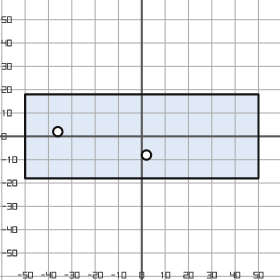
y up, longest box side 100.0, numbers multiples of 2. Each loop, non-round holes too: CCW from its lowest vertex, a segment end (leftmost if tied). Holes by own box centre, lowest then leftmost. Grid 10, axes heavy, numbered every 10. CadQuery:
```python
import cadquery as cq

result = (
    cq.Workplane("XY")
    .moveTo(-50.0, -18.0)
    .lineTo(50.0, -18.0)
    .lineTo(50.0, 18.0)
    .lineTo(-50.0, 18.0)
    .close()
    .moveTo(2.0, -8.0)
    .circle(2.0)
    .moveTo(-36.0, 2.0)
    .circle(2.0)
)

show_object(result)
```